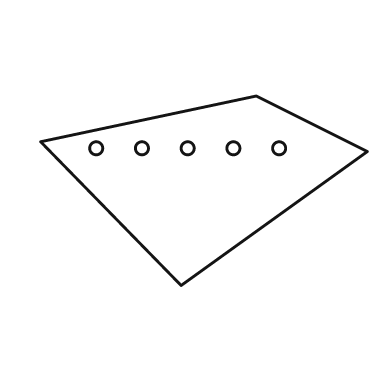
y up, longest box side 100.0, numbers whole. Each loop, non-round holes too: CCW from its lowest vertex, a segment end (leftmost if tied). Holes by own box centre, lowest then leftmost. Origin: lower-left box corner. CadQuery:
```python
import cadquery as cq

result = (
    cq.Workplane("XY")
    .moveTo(43.0, 0.0)
    .lineTo(100.0, 41.0)
    .lineTo(66.0, 58.0)
    .lineTo(0.0, 44.0)
    .close()
    .moveTo(17.0, 42.0)
    .circle(2.0)
    .moveTo(31.0, 42.0)
    .circle(2.0)
    .moveTo(45.0, 42.0)
    .circle(2.0)
    .moveTo(59.0, 42.0)
    .circle(2.0)
    .moveTo(73.0, 42.0)
    .circle(2.0)
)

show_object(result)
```